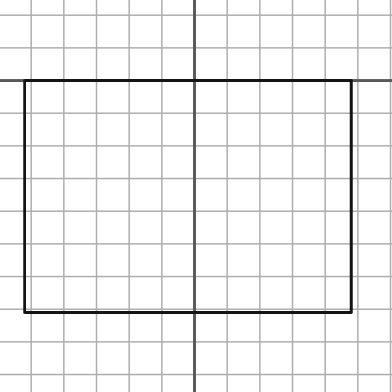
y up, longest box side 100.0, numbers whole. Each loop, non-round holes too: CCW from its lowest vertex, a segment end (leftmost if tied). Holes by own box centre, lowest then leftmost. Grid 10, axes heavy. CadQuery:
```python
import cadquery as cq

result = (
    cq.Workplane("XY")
    .moveTo(-52.0, -71.0)
    .lineTo(48.0, -71.0)
    .lineTo(48.0, 0.0)
    .lineTo(-52.0, 0.0)
    .close()
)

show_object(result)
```